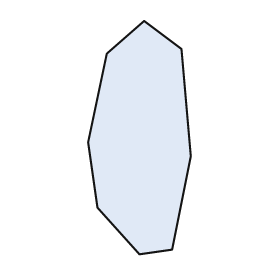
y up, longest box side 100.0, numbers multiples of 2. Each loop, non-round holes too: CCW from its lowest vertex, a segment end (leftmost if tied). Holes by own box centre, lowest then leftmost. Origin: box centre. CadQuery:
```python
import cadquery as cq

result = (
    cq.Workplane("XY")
    .moveTo(0.0, -50.0)
    .lineTo(14.0, -48.0)
    .lineTo(22.0, -8.0)
    .lineTo(18.0, 38.0)
    .lineTo(2.0, 50.0)
    .lineTo(-14.0, 36.0)
    .lineTo(-22.0, -2.0)
    .lineTo(-18.0, -30.0)
    .close()
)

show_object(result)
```